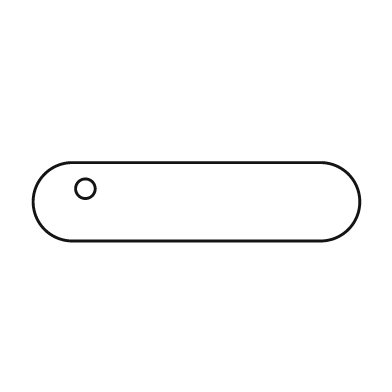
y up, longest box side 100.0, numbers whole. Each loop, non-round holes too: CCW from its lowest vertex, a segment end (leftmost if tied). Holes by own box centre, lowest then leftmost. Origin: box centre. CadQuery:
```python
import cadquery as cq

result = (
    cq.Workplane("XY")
    .moveTo(-38.0, -12.0)
    .lineTo(38.0, -12.0)
    .threePointArc((50.0, 0.0), (38.0, 12.0))
    .lineTo(-38.0, 12.0)
    .threePointArc((-50.0, 0.0), (-38.0, -12.0))
    .close()
    .moveTo(-34.0, 4.0)
    .circle(3.0)
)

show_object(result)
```